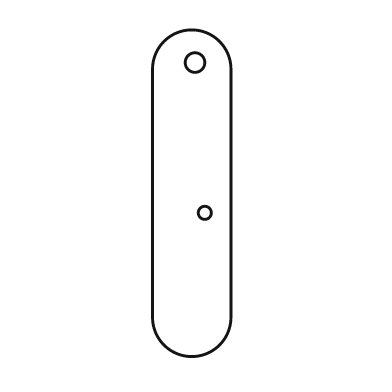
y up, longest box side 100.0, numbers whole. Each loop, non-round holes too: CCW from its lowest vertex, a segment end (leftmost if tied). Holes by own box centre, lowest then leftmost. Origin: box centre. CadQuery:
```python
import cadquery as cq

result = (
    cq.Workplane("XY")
    .moveTo(-12.0, -38.0)
    .threePointArc((0.0, -50.0), (12.0, -38.0))
    .lineTo(12.0, 38.0)
    .threePointArc((0.0, 50.0), (-12.0, 38.0))
    .close()
    .moveTo(4.0, -6.0)
    .circle(2.0)
    .moveTo(1.0, 40.0)
    .circle(3.0)
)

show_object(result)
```